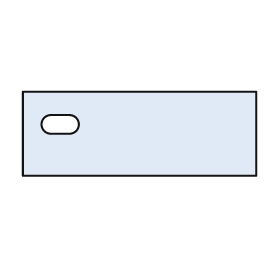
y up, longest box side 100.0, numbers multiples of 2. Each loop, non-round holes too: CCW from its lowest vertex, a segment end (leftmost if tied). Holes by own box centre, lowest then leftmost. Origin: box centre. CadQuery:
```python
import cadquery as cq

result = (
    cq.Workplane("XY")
    .moveTo(-50.0, -18.0)
    .lineTo(50.0, -18.0)
    .lineTo(50.0, 18.0)
    .lineTo(-50.0, 18.0)
    .close()
    .moveTo(-38.0, 0.0)
    .lineTo(-30.0, 0.0)
    .threePointArc((-26.0, 4.0), (-30.0, 8.0))
    .lineTo(-38.0, 8.0)
    .threePointArc((-42.0, 4.0), (-38.0, 0.0))
    .close()
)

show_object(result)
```